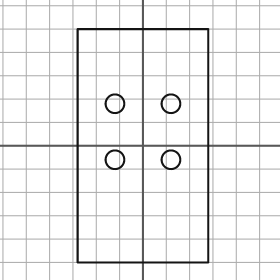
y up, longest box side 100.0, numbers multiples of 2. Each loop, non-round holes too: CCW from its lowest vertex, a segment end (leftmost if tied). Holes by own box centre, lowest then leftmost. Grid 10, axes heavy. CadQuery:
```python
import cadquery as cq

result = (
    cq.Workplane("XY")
    .moveTo(-28.0, -50.0)
    .lineTo(28.0, -50.0)
    .lineTo(28.0, 50.0)
    .lineTo(-28.0, 50.0)
    .close()
    .moveTo(-12.0, -6.0)
    .circle(4.0)
    .moveTo(12.0, -6.0)
    .circle(4.0)
    .moveTo(-12.0, 18.0)
    .circle(4.0)
    .moveTo(12.0, 18.0)
    .circle(4.0)
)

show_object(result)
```